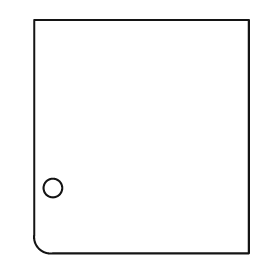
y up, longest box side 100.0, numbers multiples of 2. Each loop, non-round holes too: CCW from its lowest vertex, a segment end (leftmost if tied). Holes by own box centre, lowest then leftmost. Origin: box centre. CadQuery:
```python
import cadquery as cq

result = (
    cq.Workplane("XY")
    .moveTo(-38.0, -50.0)
    .lineTo(46.0, -50.0)
    .lineTo(46.0, 50.0)
    .lineTo(-46.0, 50.0)
    .lineTo(-46.0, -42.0)
    .threePointArc((-44.0, -48.0), (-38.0, -50.0))
    .close()
    .moveTo(-38.0, -22.0)
    .circle(4.0)
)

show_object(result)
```